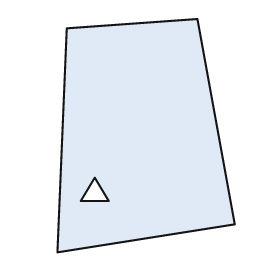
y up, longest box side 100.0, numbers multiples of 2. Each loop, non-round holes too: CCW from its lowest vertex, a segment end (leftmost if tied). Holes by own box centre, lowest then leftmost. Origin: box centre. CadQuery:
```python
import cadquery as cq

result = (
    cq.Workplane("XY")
    .moveTo(-38.0, -50.0)
    .lineTo(38.0, -38.0)
    .lineTo(22.0, 50.0)
    .lineTo(-34.0, 46.0)
    .close()
    .moveTo(-28.0, -28.0)
    .lineTo(-16.0, -28.0)
    .lineTo(-22.0, -18.0)
    .close()
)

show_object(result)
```